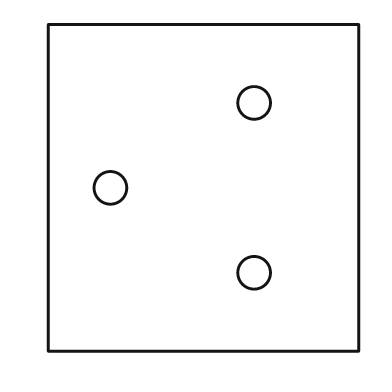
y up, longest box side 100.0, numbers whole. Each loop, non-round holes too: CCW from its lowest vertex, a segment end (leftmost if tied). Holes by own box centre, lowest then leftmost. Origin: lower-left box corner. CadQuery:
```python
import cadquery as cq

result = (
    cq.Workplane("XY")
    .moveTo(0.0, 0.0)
    .lineTo(95.0, 0.0)
    .lineTo(95.0, 100.0)
    .lineTo(0.0, 100.0)
    .close()
    .moveTo(63.0, 24.0)
    .circle(5.0)
    .moveTo(19.0, 50.0)
    .circle(5.0)
    .moveTo(63.0, 76.0)
    .circle(5.0)
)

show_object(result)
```